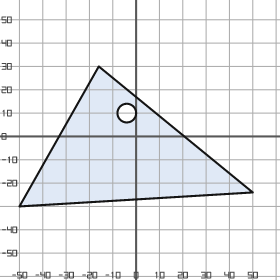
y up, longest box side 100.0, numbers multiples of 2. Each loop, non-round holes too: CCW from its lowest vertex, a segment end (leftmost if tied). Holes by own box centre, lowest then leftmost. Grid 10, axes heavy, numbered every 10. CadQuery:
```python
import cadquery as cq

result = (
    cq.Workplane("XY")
    .moveTo(-50.0, -30.0)
    .lineTo(50.0, -24.0)
    .lineTo(-16.0, 30.0)
    .close()
    .moveTo(-4.0, 10.0)
    .circle(4.0)
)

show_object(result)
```